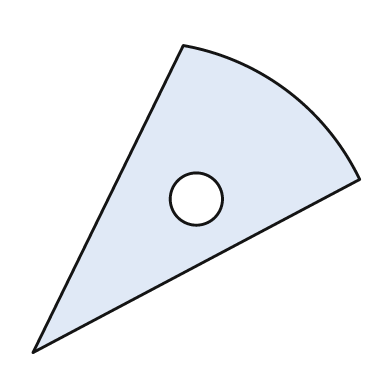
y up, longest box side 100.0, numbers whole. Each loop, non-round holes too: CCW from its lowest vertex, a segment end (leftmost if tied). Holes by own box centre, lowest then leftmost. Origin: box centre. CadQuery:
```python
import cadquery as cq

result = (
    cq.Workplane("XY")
    .moveTo(-50.0, -47.0)
    .lineTo(50.0, 6.0)
    .threePointArc((28.0, 33.0), (-4.0, 47.0))
    .close()
    .moveTo(0.0, 0.0)
    .circle(8.0)
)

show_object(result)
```